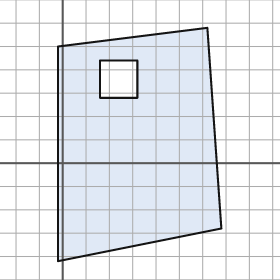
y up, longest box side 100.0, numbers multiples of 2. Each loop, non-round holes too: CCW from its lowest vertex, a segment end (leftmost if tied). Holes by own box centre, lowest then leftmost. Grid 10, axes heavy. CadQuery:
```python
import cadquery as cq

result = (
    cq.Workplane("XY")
    .moveTo(-2.0, -42.0)
    .lineTo(68.0, -28.0)
    .lineTo(62.0, 58.0)
    .lineTo(-2.0, 50.0)
    .close()
    .moveTo(16.0, 28.0)
    .lineTo(32.0, 28.0)
    .lineTo(32.0, 44.0)
    .lineTo(16.0, 44.0)
    .close()
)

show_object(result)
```